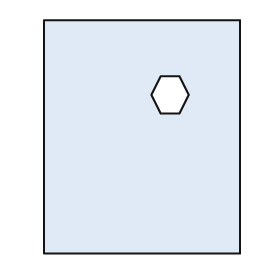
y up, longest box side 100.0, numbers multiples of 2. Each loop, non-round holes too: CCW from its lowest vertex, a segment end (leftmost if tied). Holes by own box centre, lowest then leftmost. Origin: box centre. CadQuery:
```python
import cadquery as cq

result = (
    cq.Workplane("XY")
    .moveTo(-42.0, -50.0)
    .lineTo(42.0, -50.0)
    .lineTo(42.0, 50.0)
    .lineTo(-42.0, 50.0)
    .close()
    .moveTo(8.0, 10.0)
    .lineTo(16.0, 10.0)
    .lineTo(20.0, 18.0)
    .lineTo(16.0, 26.0)
    .lineTo(8.0, 26.0)
    .lineTo(4.0, 18.0)
    .close()
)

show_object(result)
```